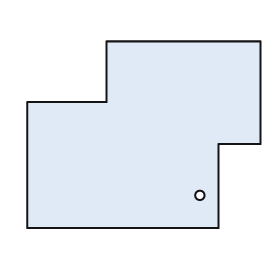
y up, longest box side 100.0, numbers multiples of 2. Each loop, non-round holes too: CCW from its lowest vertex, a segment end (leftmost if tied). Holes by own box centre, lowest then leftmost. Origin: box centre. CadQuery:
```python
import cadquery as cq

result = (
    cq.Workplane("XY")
    .moveTo(-50.0, -40.0)
    .lineTo(32.0, -40.0)
    .lineTo(32.0, -4.0)
    .lineTo(50.0, -4.0)
    .lineTo(50.0, 40.0)
    .lineTo(-16.0, 40.0)
    .lineTo(-16.0, 14.0)
    .lineTo(-50.0, 14.0)
    .close()
    .moveTo(24.0, -26.0)
    .circle(2.0)
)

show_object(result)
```